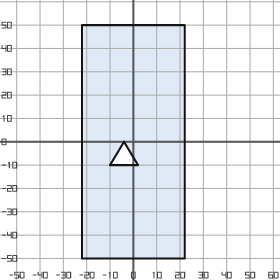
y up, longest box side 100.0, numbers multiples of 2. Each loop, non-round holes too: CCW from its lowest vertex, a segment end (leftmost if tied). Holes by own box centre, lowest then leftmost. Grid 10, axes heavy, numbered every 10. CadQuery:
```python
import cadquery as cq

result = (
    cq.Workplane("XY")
    .moveTo(-22.0, -50.0)
    .lineTo(22.0, -50.0)
    .lineTo(22.0, 50.0)
    .lineTo(-22.0, 50.0)
    .close()
    .moveTo(-10.0, -10.0)
    .lineTo(2.0, -10.0)
    .lineTo(-4.0, 0.0)
    .close()
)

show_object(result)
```